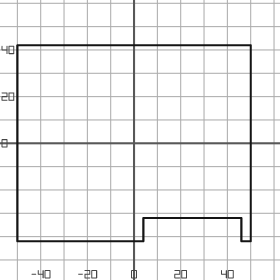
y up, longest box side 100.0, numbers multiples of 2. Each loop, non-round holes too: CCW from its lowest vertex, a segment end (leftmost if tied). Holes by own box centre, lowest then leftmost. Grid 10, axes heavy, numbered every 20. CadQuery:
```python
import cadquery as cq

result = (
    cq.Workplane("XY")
    .moveTo(-50.0, -42.0)
    .lineTo(4.0, -42.0)
    .lineTo(4.0, -32.0)
    .lineTo(46.0, -32.0)
    .lineTo(46.0, -42.0)
    .lineTo(50.0, -42.0)
    .lineTo(50.0, 42.0)
    .lineTo(-50.0, 42.0)
    .close()
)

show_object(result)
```